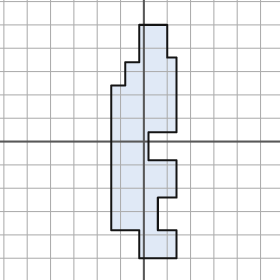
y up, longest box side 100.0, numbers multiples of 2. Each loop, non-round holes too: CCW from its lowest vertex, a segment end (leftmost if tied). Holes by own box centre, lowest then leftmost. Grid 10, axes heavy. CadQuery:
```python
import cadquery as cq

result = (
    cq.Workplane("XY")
    .moveTo(-2.0, -50.0)
    .lineTo(14.0, -50.0)
    .lineTo(14.0, -38.0)
    .lineTo(6.0, -38.0)
    .lineTo(6.0, -24.0)
    .lineTo(14.0, -24.0)
    .lineTo(14.0, -8.0)
    .lineTo(2.0, -8.0)
    .lineTo(2.0, 4.0)
    .lineTo(14.0, 4.0)
    .lineTo(14.0, 36.0)
    .lineTo(10.0, 36.0)
    .lineTo(10.0, 50.0)
    .lineTo(-2.0, 50.0)
    .lineTo(-2.0, 34.0)
    .lineTo(-8.0, 34.0)
    .lineTo(-8.0, 24.0)
    .lineTo(-14.0, 24.0)
    .lineTo(-14.0, -38.0)
    .lineTo(-2.0, -38.0)
    .close()
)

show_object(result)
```